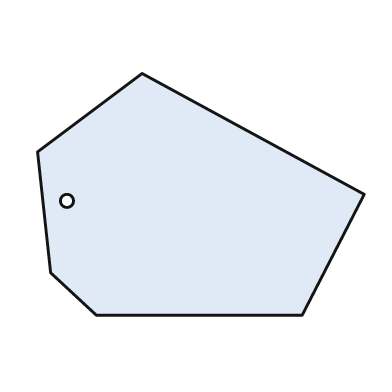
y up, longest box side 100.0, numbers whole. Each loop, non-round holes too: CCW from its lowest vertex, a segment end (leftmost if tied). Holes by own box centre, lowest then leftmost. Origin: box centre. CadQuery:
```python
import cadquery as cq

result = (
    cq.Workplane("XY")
    .moveTo(-32.0, -37.0)
    .lineTo(31.0, -37.0)
    .lineTo(50.0, 0.0)
    .lineTo(-18.0, 37.0)
    .lineTo(-50.0, 13.0)
    .lineTo(-46.0, -24.0)
    .close()
    .moveTo(-41.0, -2.0)
    .circle(2.0)
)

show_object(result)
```